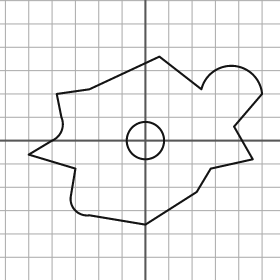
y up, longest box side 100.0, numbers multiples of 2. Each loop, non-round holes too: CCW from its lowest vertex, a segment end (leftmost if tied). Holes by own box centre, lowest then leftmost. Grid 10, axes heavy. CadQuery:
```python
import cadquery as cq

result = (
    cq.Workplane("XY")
    .moveTo(0.0, -36.0)
    .lineTo(22.0, -22.0)
    .lineTo(28.0, -12.0)
    .lineTo(46.0, -8.0)
    .lineTo(38.0, 6.0)
    .lineTo(50.0, 20.0)
    .threePointArc((38.0, 32.0), (24.0, 22.0))
    .lineTo(6.0, 36.0)
    .lineTo(-24.0, 22.0)
    .lineTo(-38.0, 20.0)
    .lineTo(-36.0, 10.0)
    .threePointArc((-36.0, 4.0), (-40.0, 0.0))
    .lineTo(-50.0, -6.0)
    .lineTo(-30.0, -12.0)
    .lineTo(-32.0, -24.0)
    .threePointArc((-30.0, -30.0), (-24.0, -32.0))
    .close()
    .moveTo(0.0, 0.0)
    .circle(8.0)
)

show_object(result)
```